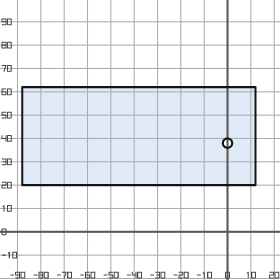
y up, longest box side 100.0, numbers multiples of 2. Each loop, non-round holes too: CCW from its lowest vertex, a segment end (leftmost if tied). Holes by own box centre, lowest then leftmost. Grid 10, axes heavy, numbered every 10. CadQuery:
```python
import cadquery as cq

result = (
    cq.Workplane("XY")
    .moveTo(-88.0, 20.0)
    .lineTo(12.0, 20.0)
    .lineTo(12.0, 62.0)
    .lineTo(-88.0, 62.0)
    .close()
    .moveTo(0.0, 38.0)
    .circle(2.0)
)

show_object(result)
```